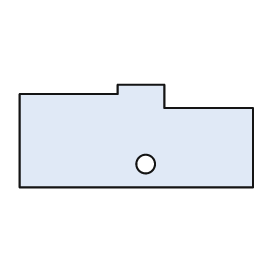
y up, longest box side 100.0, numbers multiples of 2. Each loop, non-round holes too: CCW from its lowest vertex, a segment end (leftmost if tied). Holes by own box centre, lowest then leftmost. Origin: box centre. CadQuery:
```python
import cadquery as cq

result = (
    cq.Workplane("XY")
    .moveTo(-50.0, -22.0)
    .lineTo(50.0, -22.0)
    .lineTo(50.0, 12.0)
    .lineTo(12.0, 12.0)
    .lineTo(12.0, 22.0)
    .lineTo(-8.0, 22.0)
    .lineTo(-8.0, 18.0)
    .lineTo(-50.0, 18.0)
    .close()
    .moveTo(4.0, -12.0)
    .circle(4.0)
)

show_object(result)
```